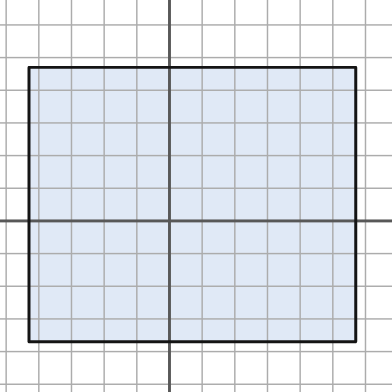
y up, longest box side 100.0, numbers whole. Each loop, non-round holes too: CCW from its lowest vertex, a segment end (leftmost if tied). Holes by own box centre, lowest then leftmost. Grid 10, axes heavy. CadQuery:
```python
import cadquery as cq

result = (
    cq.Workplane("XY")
    .moveTo(-43.0, -37.0)
    .lineTo(57.0, -37.0)
    .lineTo(57.0, 47.0)
    .lineTo(-43.0, 47.0)
    .close()
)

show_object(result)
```